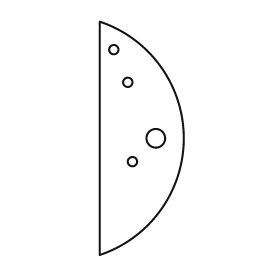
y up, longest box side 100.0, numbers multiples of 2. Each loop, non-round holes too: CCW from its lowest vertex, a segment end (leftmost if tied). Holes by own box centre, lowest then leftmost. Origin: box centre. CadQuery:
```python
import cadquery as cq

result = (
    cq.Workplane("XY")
    .moveTo(-18.0, -50.0)
    .threePointArc((18.0, 0.0), (-18.0, 50.0))
    .close()
    .moveTo(-4.0, -10.0)
    .circle(2.0)
    .moveTo(6.0, 0.0)
    .circle(4.0)
    .moveTo(-6.0, 24.0)
    .circle(2.0)
    .moveTo(-12.0, 38.0)
    .circle(2.0)
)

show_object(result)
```